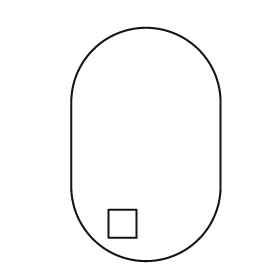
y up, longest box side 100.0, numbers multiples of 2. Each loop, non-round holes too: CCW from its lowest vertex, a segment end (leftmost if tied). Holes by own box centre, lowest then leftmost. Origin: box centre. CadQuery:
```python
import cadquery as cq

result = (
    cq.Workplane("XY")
    .moveTo(-32.0, -18.0)
    .threePointArc((0.0, -50.0), (32.0, -18.0))
    .lineTo(32.0, 18.0)
    .threePointArc((0.0, 50.0), (-32.0, 18.0))
    .close()
    .moveTo(-16.0, -40.0)
    .lineTo(-4.0, -40.0)
    .lineTo(-4.0, -28.0)
    .lineTo(-16.0, -28.0)
    .close()
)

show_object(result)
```